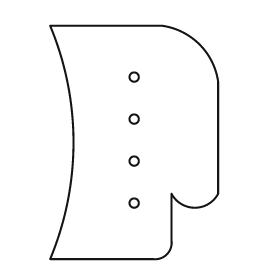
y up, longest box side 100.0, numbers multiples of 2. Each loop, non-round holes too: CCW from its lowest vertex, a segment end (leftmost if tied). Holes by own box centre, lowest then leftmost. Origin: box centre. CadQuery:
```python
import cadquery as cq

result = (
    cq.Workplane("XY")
    .moveTo(-36.0, -50.0)
    .lineTo(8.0, -50.0)
    .threePointArc((14.0, -48.0), (16.0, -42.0))
    .lineTo(16.0, -22.0)
    .threePointArc((26.0, -28.0), (36.0, -22.0))
    .lineTo(36.0, 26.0)
    .threePointArc((28.0, 42.0), (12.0, 50.0))
    .lineTo(-36.0, 50.0)
    .threePointArc((-26.0, 0.0), (-36.0, -50.0))
    .close()
    .moveTo(0.0, -26.0)
    .circle(2.0)
    .moveTo(0.0, -8.0)
    .circle(2.0)
    .moveTo(0.0, 10.0)
    .circle(2.0)
    .moveTo(0.0, 28.0)
    .circle(2.0)
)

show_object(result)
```